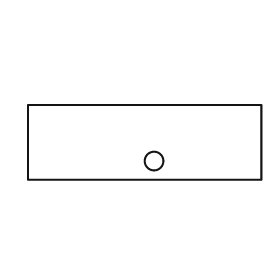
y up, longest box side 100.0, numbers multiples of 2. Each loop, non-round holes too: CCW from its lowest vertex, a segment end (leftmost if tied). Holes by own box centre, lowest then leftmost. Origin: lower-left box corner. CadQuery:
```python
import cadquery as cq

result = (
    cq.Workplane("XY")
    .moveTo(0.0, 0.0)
    .lineTo(100.0, 0.0)
    .lineTo(100.0, 32.0)
    .lineTo(0.0, 32.0)
    .close()
    .moveTo(54.0, 8.0)
    .circle(4.0)
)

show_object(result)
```